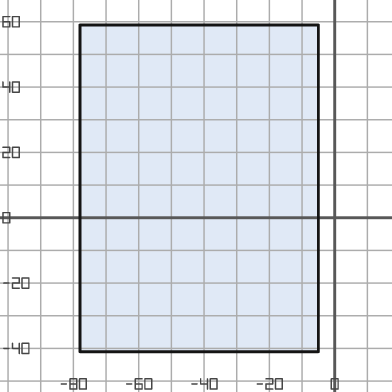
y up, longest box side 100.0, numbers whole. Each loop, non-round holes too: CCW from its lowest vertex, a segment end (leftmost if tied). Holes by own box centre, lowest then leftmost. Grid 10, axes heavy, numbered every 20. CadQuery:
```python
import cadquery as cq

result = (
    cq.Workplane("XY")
    .moveTo(-78.0, -41.0)
    .lineTo(-5.0, -41.0)
    .lineTo(-5.0, 59.0)
    .lineTo(-78.0, 59.0)
    .close()
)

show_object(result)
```